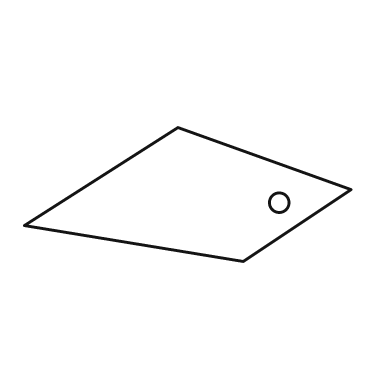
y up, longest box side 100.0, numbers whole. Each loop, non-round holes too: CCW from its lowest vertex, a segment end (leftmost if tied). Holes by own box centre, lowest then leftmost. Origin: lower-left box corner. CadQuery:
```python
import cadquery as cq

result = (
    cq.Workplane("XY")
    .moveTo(67.0, 0.0)
    .lineTo(100.0, 22.0)
    .lineTo(47.0, 41.0)
    .lineTo(0.0, 11.0)
    .close()
    .moveTo(78.0, 18.0)
    .circle(3.0)
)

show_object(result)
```